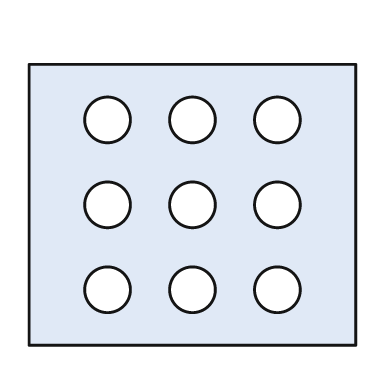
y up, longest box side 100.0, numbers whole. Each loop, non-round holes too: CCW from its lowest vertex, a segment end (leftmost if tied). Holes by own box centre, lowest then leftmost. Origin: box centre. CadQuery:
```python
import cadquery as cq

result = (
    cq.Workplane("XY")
    .moveTo(-50.0, -43.0)
    .lineTo(50.0, -43.0)
    .lineTo(50.0, 43.0)
    .lineTo(-50.0, 43.0)
    .close()
    .moveTo(-26.0, -26.0)
    .circle(7.0)
    .moveTo(0.0, -26.0)
    .circle(7.0)
    .moveTo(26.0, -26.0)
    .circle(7.0)
    .moveTo(-26.0, 0.0)
    .circle(7.0)
    .moveTo(0.0, 0.0)
    .circle(7.0)
    .moveTo(26.0, 0.0)
    .circle(7.0)
    .moveTo(-26.0, 26.0)
    .circle(7.0)
    .moveTo(0.0, 26.0)
    .circle(7.0)
    .moveTo(26.0, 26.0)
    .circle(7.0)
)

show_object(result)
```